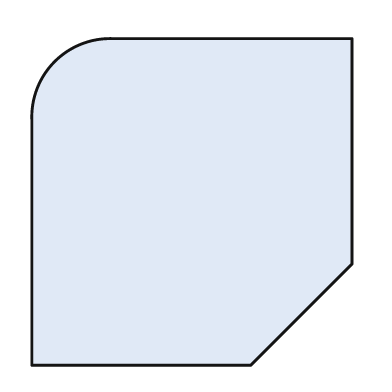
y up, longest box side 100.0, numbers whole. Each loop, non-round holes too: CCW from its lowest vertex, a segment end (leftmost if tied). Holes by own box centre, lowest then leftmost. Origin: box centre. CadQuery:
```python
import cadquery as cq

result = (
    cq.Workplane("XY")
    .moveTo(-49.0, -50.0)
    .lineTo(18.0, -50.0)
    .lineTo(49.0, -19.0)
    .lineTo(49.0, 50.0)
    .lineTo(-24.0, 50.0)
    .threePointArc((-42.0, 43.0), (-49.0, 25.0))
    .close()
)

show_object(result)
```